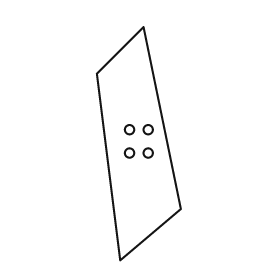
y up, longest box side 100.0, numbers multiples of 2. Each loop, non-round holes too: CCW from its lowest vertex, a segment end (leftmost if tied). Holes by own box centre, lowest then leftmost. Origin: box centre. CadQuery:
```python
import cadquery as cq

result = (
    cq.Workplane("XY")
    .moveTo(-8.0, -50.0)
    .lineTo(18.0, -28.0)
    .lineTo(2.0, 50.0)
    .lineTo(-18.0, 30.0)
    .close()
    .moveTo(-4.0, -4.0)
    .circle(2.0)
    .moveTo(4.0, -4.0)
    .circle(2.0)
    .moveTo(-4.0, 6.0)
    .circle(2.0)
    .moveTo(4.0, 6.0)
    .circle(2.0)
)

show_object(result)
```